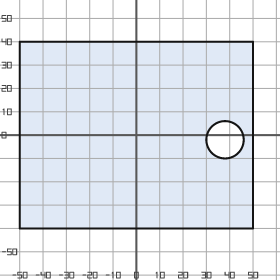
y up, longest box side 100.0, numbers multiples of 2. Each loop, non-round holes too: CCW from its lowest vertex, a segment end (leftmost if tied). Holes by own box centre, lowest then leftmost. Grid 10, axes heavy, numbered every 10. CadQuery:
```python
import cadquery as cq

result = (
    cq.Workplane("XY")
    .moveTo(-50.0, -40.0)
    .lineTo(50.0, -40.0)
    .lineTo(50.0, 40.0)
    .lineTo(-50.0, 40.0)
    .close()
    .moveTo(38.0, -2.0)
    .circle(8.0)
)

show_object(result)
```